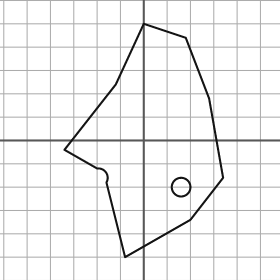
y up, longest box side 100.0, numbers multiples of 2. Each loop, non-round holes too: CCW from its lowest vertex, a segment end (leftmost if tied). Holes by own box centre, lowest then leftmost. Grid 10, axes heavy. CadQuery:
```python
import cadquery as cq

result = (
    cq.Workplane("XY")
    .moveTo(-8.0, -50.0)
    .lineTo(20.0, -34.0)
    .lineTo(34.0, -16.0)
    .lineTo(28.0, 18.0)
    .lineTo(18.0, 44.0)
    .lineTo(0.0, 50.0)
    .lineTo(-12.0, 24.0)
    .lineTo(-34.0, -4.0)
    .lineTo(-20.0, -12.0)
    .threePointArc((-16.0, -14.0), (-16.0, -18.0))
    .close()
    .moveTo(16.0, -20.0)
    .circle(4.0)
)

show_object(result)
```